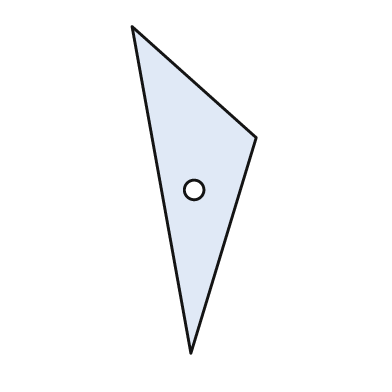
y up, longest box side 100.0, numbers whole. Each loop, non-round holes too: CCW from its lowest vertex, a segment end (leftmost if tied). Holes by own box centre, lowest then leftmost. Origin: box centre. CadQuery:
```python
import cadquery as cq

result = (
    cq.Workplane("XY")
    .moveTo(-1.0, -50.0)
    .lineTo(19.0, 16.0)
    .lineTo(-19.0, 50.0)
    .close()
    .moveTo(0.0, 0.0)
    .circle(3.0)
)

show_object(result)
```